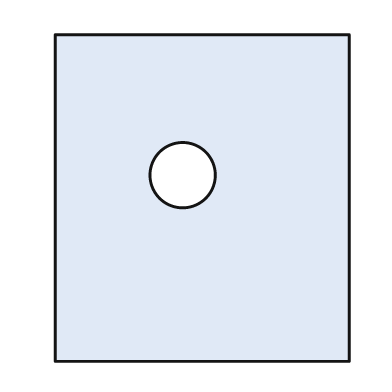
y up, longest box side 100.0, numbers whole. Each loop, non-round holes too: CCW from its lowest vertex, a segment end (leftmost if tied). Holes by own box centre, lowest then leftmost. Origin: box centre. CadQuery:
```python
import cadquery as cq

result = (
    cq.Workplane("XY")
    .moveTo(-45.0, -50.0)
    .lineTo(45.0, -50.0)
    .lineTo(45.0, 50.0)
    .lineTo(-45.0, 50.0)
    .close()
    .moveTo(-6.0, 7.0)
    .circle(10.0)
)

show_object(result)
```